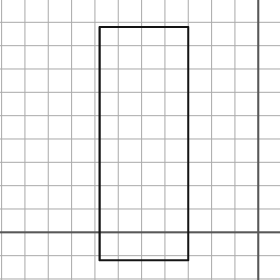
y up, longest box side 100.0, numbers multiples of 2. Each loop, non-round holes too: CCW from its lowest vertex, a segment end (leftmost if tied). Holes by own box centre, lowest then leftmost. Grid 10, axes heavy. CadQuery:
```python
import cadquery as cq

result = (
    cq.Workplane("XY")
    .moveTo(-68.0, -12.0)
    .lineTo(-30.0, -12.0)
    .lineTo(-30.0, 88.0)
    .lineTo(-68.0, 88.0)
    .close()
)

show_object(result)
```